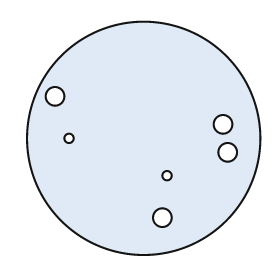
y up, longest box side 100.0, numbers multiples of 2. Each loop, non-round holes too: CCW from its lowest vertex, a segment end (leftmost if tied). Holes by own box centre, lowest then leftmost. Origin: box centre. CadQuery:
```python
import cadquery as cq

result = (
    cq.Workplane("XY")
    .moveTo(0.0, 0.0)
    .circle(50.0)
    .moveTo(8.0, -34.0)
    .circle(4.0)
    .moveTo(10.0, -16.0)
    .circle(2.0)
    .moveTo(36.0, -6.0)
    .circle(4.0)
    .moveTo(-32.0, 0.0)
    .circle(2.0)
    .moveTo(34.0, 6.0)
    .circle(4.0)
    .moveTo(-38.0, 18.0)
    .circle(4.0)
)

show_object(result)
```